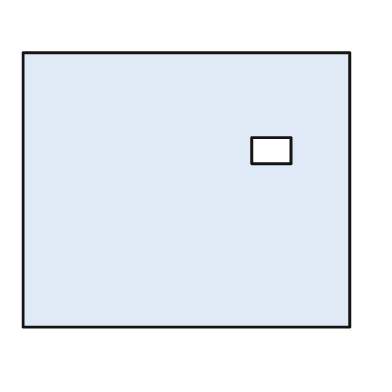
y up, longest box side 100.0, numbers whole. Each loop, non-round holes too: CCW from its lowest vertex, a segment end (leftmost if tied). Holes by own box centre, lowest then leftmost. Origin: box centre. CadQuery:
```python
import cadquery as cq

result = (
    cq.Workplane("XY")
    .moveTo(-50.0, -42.0)
    .lineTo(50.0, -42.0)
    .lineTo(50.0, 42.0)
    .lineTo(-50.0, 42.0)
    .close()
    .moveTo(20.0, 8.0)
    .lineTo(32.0, 8.0)
    .lineTo(32.0, 16.0)
    .lineTo(20.0, 16.0)
    .close()
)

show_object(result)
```